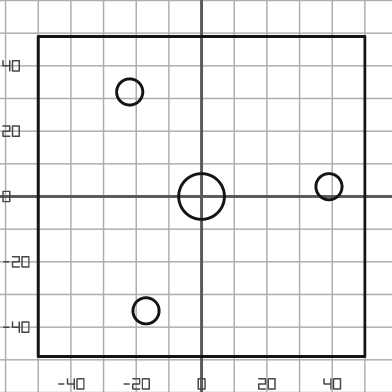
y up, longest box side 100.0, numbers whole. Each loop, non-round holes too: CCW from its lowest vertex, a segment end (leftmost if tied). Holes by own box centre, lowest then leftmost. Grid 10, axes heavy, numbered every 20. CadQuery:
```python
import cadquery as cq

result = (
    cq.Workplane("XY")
    .moveTo(-50.0, -49.0)
    .lineTo(50.0, -49.0)
    .lineTo(50.0, 49.0)
    .lineTo(-50.0, 49.0)
    .close()
    .moveTo(-17.0, -35.0)
    .circle(4.0)
    .moveTo(0.0, 0.0)
    .circle(7.0)
    .moveTo(39.0, 3.0)
    .circle(4.0)
    .moveTo(-22.0, 32.0)
    .circle(4.0)
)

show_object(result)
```